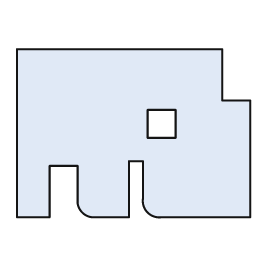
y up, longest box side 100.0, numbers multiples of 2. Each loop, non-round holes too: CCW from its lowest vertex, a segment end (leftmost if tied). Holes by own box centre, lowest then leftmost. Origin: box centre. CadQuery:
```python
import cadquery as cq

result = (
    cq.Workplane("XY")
    .moveTo(-50.0, -36.0)
    .lineTo(-36.0, -36.0)
    .lineTo(-36.0, -14.0)
    .lineTo(-24.0, -14.0)
    .lineTo(-24.0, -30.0)
    .threePointArc((-22.0, -34.0), (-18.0, -36.0))
    .lineTo(-2.0, -36.0)
    .lineTo(-2.0, -12.0)
    .lineTo(4.0, -12.0)
    .lineTo(4.0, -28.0)
    .threePointArc((6.0, -34.0), (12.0, -36.0))
    .lineTo(50.0, -36.0)
    .lineTo(50.0, 14.0)
    .lineTo(38.0, 14.0)
    .lineTo(38.0, 36.0)
    .lineTo(-50.0, 36.0)
    .close()
    .moveTo(6.0, -2.0)
    .lineTo(18.0, -2.0)
    .lineTo(18.0, 10.0)
    .lineTo(6.0, 10.0)
    .close()
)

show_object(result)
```